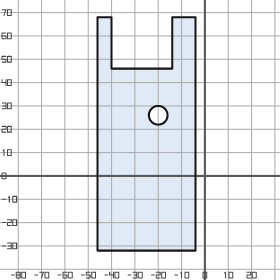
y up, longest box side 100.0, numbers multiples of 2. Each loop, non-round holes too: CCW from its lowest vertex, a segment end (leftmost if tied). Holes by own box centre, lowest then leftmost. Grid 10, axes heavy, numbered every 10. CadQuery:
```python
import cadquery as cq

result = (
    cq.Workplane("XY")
    .moveTo(-46.0, -32.0)
    .lineTo(-4.0, -32.0)
    .lineTo(-4.0, 68.0)
    .lineTo(-14.0, 68.0)
    .lineTo(-14.0, 46.0)
    .lineTo(-40.0, 46.0)
    .lineTo(-40.0, 68.0)
    .lineTo(-46.0, 68.0)
    .close()
    .moveTo(-20.0, 26.0)
    .circle(4.0)
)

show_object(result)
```